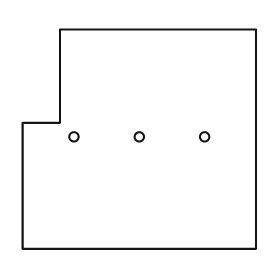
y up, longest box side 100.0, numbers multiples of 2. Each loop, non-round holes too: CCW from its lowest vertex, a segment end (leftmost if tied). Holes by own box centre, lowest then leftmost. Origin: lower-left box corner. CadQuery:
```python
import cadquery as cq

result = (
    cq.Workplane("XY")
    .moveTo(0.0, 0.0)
    .lineTo(100.0, 0.0)
    .lineTo(100.0, 94.0)
    .lineTo(16.0, 94.0)
    .lineTo(16.0, 54.0)
    .lineTo(0.0, 54.0)
    .close()
    .moveTo(22.0, 48.0)
    .circle(2.0)
    .moveTo(50.0, 48.0)
    .circle(2.0)
    .moveTo(78.0, 48.0)
    .circle(2.0)
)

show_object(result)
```